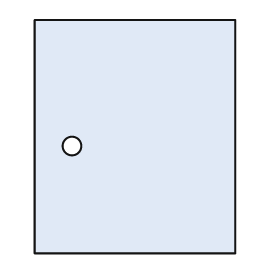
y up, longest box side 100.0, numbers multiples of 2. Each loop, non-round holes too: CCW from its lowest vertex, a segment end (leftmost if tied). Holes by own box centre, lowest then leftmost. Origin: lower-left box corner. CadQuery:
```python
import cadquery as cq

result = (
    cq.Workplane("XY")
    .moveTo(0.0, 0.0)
    .lineTo(86.0, 0.0)
    .lineTo(86.0, 100.0)
    .lineTo(0.0, 100.0)
    .close()
    .moveTo(16.0, 46.0)
    .circle(4.0)
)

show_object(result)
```